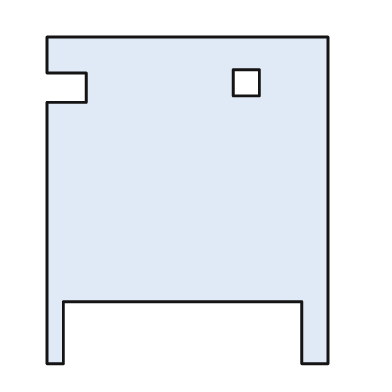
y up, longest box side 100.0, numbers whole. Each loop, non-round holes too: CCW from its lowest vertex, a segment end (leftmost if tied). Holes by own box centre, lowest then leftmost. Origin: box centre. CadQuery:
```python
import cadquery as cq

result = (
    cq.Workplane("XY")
    .moveTo(-43.0, -50.0)
    .lineTo(-38.0, -50.0)
    .lineTo(-38.0, -31.0)
    .lineTo(35.0, -31.0)
    .lineTo(35.0, -50.0)
    .lineTo(43.0, -50.0)
    .lineTo(43.0, 50.0)
    .lineTo(-43.0, 50.0)
    .lineTo(-43.0, 39.0)
    .lineTo(-31.0, 39.0)
    .lineTo(-31.0, 30.0)
    .lineTo(-43.0, 30.0)
    .close()
    .moveTo(14.0, 32.0)
    .lineTo(22.0, 32.0)
    .lineTo(22.0, 40.0)
    .lineTo(14.0, 40.0)
    .close()
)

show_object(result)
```